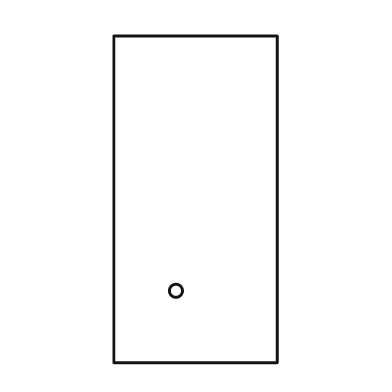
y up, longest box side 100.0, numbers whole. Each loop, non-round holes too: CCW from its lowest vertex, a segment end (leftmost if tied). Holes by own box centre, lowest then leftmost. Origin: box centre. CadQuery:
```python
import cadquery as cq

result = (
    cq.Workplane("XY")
    .moveTo(-25.0, -50.0)
    .lineTo(25.0, -50.0)
    .lineTo(25.0, 50.0)
    .lineTo(-25.0, 50.0)
    .close()
    .moveTo(-6.0, -28.0)
    .circle(2.0)
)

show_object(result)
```